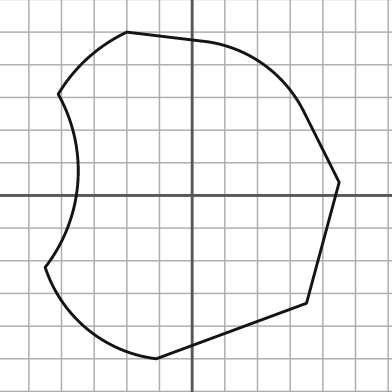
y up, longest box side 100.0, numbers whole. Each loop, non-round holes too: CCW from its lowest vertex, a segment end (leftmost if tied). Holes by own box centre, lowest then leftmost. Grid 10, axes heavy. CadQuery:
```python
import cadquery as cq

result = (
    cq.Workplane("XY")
    .moveTo(-11.0, -50.0)
    .lineTo(35.0, -33.0)
    .lineTo(45.0, 4.0)
    .lineTo(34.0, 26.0)
    .threePointArc((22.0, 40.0), (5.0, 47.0))
    .lineTo(-20.0, 50.0)
    .threePointArc((-32.0, 42.0), (-41.0, 31.0))
    .threePointArc((-35.0, 4.0), (-45.0, -22.0))
    .threePointArc((-32.0, -41.0), (-11.0, -50.0))
    .close()
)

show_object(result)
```